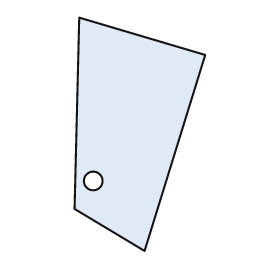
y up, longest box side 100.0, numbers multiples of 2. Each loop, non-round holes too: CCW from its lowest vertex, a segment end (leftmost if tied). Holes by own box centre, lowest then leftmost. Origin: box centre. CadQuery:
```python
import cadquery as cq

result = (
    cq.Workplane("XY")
    .moveTo(2.0, -50.0)
    .lineTo(28.0, 34.0)
    .lineTo(-26.0, 50.0)
    .lineTo(-28.0, -32.0)
    .close()
    .moveTo(-20.0, -20.0)
    .circle(4.0)
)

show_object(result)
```